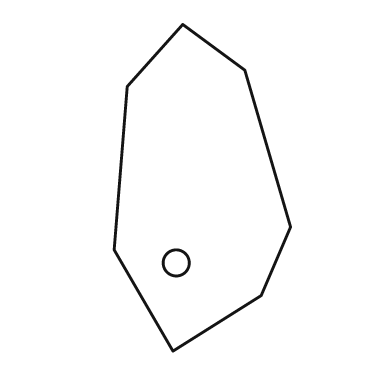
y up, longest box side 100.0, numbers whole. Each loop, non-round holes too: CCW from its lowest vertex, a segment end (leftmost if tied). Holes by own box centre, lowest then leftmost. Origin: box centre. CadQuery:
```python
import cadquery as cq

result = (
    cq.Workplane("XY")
    .moveTo(-9.0, -50.0)
    .lineTo(18.0, -33.0)
    .lineTo(27.0, -12.0)
    .lineTo(13.0, 36.0)
    .lineTo(-6.0, 50.0)
    .lineTo(-23.0, 31.0)
    .lineTo(-27.0, -19.0)
    .close()
    .moveTo(-8.0, -23.0)
    .circle(4.0)
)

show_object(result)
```